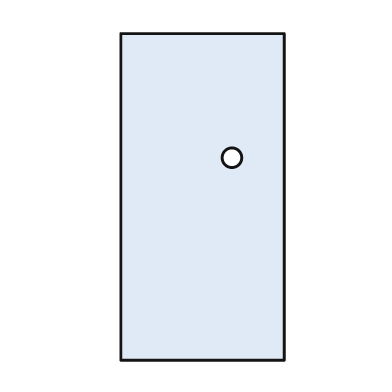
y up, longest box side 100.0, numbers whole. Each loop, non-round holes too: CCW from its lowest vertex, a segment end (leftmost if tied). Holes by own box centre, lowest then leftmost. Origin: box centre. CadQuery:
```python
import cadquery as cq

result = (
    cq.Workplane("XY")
    .moveTo(-25.0, -50.0)
    .lineTo(25.0, -50.0)
    .lineTo(25.0, 50.0)
    .lineTo(-25.0, 50.0)
    .close()
    .moveTo(9.0, 12.0)
    .circle(3.0)
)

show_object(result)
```